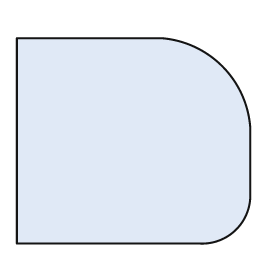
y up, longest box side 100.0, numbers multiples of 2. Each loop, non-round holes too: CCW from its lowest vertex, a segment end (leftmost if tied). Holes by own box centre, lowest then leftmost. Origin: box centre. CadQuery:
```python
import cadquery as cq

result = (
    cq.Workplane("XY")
    .moveTo(-50.0, -44.0)
    .lineTo(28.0, -44.0)
    .threePointArc((44.0, -38.0), (50.0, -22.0))
    .lineTo(50.0, 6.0)
    .threePointArc((38.0, 32.0), (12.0, 44.0))
    .lineTo(-50.0, 44.0)
    .close()
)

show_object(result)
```